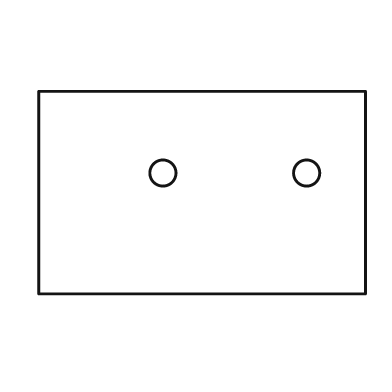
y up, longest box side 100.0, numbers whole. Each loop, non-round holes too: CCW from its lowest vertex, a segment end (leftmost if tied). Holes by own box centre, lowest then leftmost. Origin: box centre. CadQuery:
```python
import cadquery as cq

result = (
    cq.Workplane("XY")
    .moveTo(-50.0, -31.0)
    .lineTo(50.0, -31.0)
    .lineTo(50.0, 31.0)
    .lineTo(-50.0, 31.0)
    .close()
    .moveTo(-12.0, 6.0)
    .circle(4.0)
    .moveTo(32.0, 6.0)
    .circle(4.0)
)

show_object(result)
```